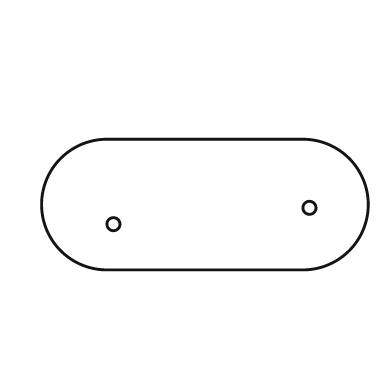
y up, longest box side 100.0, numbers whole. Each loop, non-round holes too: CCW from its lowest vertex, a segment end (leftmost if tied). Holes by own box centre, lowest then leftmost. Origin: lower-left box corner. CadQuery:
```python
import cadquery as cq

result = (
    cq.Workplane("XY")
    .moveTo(20.0, 0.0)
    .lineTo(80.0, 0.0)
    .threePointArc((100.0, 20.0), (80.0, 40.0))
    .lineTo(20.0, 40.0)
    .threePointArc((0.0, 20.0), (20.0, 0.0))
    .close()
    .moveTo(22.0, 14.0)
    .circle(2.0)
    .moveTo(82.0, 19.0)
    .circle(2.0)
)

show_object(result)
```